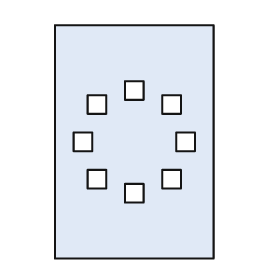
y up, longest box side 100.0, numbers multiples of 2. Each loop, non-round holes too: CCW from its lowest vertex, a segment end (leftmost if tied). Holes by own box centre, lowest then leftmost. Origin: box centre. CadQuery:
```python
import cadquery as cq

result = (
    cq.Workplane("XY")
    .moveTo(-34.0, -50.0)
    .lineTo(34.0, -50.0)
    .lineTo(34.0, 50.0)
    .lineTo(-34.0, 50.0)
    .close()
    .moveTo(-4.0, -26.0)
    .lineTo(4.0, -26.0)
    .lineTo(4.0, -18.0)
    .lineTo(-4.0, -18.0)
    .close()
    .moveTo(-20.0, -20.0)
    .lineTo(-12.0, -20.0)
    .lineTo(-12.0, -12.0)
    .lineTo(-20.0, -12.0)
    .close()
    .moveTo(12.0, -20.0)
    .lineTo(20.0, -20.0)
    .lineTo(20.0, -12.0)
    .lineTo(12.0, -12.0)
    .close()
    .moveTo(-26.0, -4.0)
    .lineTo(-18.0, -4.0)
    .lineTo(-18.0, 4.0)
    .lineTo(-26.0, 4.0)
    .close()
    .moveTo(18.0, -4.0)
    .lineTo(26.0, -4.0)
    .lineTo(26.0, 4.0)
    .lineTo(18.0, 4.0)
    .close()
    .moveTo(-20.0, 12.0)
    .lineTo(-12.0, 12.0)
    .lineTo(-12.0, 20.0)
    .lineTo(-20.0, 20.0)
    .close()
    .moveTo(12.0, 12.0)
    .lineTo(20.0, 12.0)
    .lineTo(20.0, 20.0)
    .lineTo(12.0, 20.0)
    .close()
    .moveTo(-4.0, 18.0)
    .lineTo(4.0, 18.0)
    .lineTo(4.0, 26.0)
    .lineTo(-4.0, 26.0)
    .close()
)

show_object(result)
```